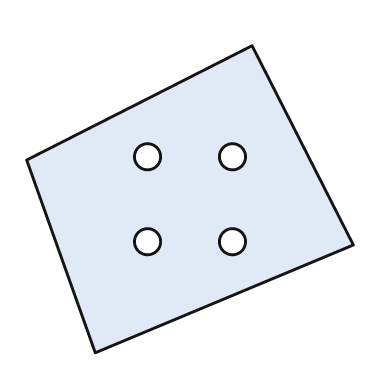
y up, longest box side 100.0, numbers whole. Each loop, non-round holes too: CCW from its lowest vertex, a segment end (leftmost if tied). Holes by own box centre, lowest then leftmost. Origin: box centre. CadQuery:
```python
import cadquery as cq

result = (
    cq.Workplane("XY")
    .moveTo(-29.0, -47.0)
    .lineTo(50.0, -14.0)
    .lineTo(19.0, 47.0)
    .lineTo(-50.0, 12.0)
    .close()
    .moveTo(-13.0, -13.0)
    .circle(4.0)
    .moveTo(13.0, -13.0)
    .circle(4.0)
    .moveTo(-13.0, 13.0)
    .circle(4.0)
    .moveTo(13.0, 13.0)
    .circle(4.0)
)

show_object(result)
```